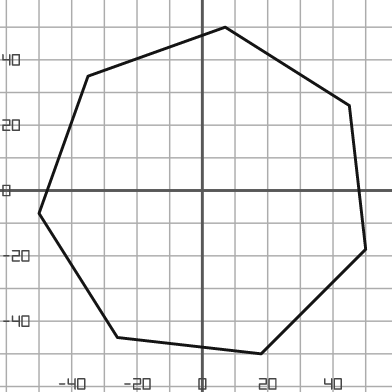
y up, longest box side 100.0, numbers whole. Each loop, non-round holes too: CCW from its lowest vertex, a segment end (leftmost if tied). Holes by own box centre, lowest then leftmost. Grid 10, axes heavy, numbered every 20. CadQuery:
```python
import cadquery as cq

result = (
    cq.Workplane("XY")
    .moveTo(18.0, -50.0)
    .lineTo(50.0, -18.0)
    .lineTo(45.0, 26.0)
    .lineTo(7.0, 50.0)
    .lineTo(-35.0, 35.0)
    .lineTo(-50.0, -7.0)
    .lineTo(-26.0, -45.0)
    .close()
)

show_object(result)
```